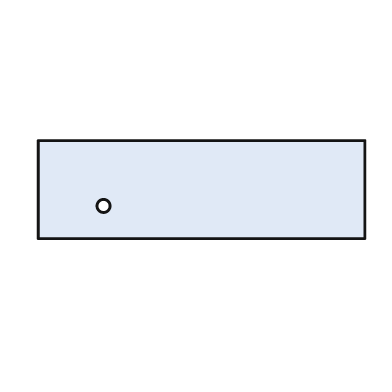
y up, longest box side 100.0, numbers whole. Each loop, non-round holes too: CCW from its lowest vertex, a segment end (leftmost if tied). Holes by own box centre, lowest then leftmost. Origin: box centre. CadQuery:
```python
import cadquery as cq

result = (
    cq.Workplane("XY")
    .moveTo(-50.0, -15.0)
    .lineTo(50.0, -15.0)
    .lineTo(50.0, 15.0)
    .lineTo(-50.0, 15.0)
    .close()
    .moveTo(-30.0, -5.0)
    .circle(2.0)
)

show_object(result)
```